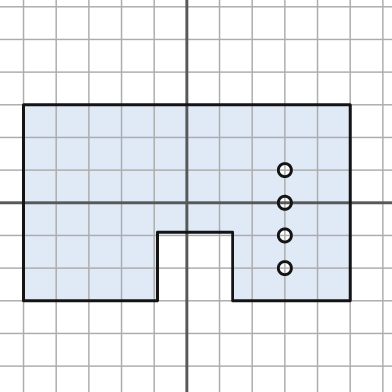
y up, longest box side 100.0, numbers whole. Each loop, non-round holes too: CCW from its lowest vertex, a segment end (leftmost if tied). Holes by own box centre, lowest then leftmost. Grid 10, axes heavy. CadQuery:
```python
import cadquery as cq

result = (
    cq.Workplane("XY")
    .moveTo(-50.0, -30.0)
    .lineTo(-9.0, -30.0)
    .lineTo(-9.0, -9.0)
    .lineTo(14.0, -9.0)
    .lineTo(14.0, -30.0)
    .lineTo(50.0, -30.0)
    .lineTo(50.0, 30.0)
    .lineTo(-50.0, 30.0)
    .close()
    .moveTo(30.0, -20.0)
    .circle(2.0)
    .moveTo(30.0, -10.0)
    .circle(2.0)
    .moveTo(30.0, 0.0)
    .circle(2.0)
    .moveTo(30.0, 10.0)
    .circle(2.0)
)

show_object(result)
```